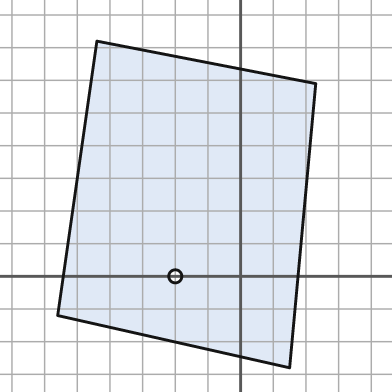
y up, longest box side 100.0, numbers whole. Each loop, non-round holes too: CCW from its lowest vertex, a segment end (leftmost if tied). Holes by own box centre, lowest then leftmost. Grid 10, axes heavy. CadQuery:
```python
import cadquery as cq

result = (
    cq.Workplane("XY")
    .moveTo(15.0, -28.0)
    .lineTo(23.0, 59.0)
    .lineTo(-44.0, 72.0)
    .lineTo(-56.0, -12.0)
    .close()
    .moveTo(-20.0, 0.0)
    .circle(2.0)
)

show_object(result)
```